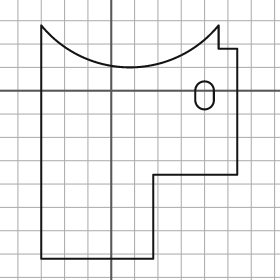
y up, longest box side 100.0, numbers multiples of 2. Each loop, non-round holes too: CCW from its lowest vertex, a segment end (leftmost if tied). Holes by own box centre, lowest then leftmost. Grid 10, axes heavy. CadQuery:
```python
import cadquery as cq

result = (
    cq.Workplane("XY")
    .moveTo(-30.0, -72.0)
    .lineTo(18.0, -72.0)
    .lineTo(18.0, -36.0)
    .lineTo(54.0, -36.0)
    .lineTo(54.0, 18.0)
    .lineTo(46.0, 18.0)
    .lineTo(46.0, 28.0)
    .threePointArc((8.0, 10.0), (-30.0, 28.0))
    .close()
    .moveTo(36.0, -4.0)
    .threePointArc((40.0, -8.0), (44.0, -4.0))
    .lineTo(44.0, 0.0)
    .threePointArc((40.0, 4.0), (36.0, 0.0))
    .close()
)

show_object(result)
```